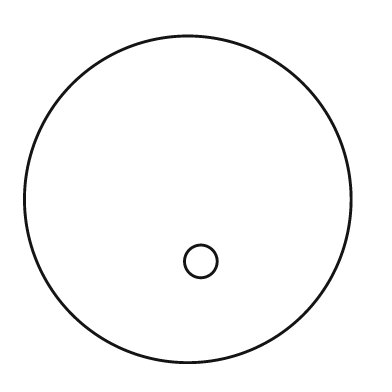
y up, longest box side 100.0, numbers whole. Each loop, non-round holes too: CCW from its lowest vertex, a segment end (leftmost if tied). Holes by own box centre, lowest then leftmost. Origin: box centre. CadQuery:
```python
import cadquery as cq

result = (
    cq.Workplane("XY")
    .moveTo(0.0, 0.0)
    .circle(50.0)
    .moveTo(4.0, -19.0)
    .circle(5.0)
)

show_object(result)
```